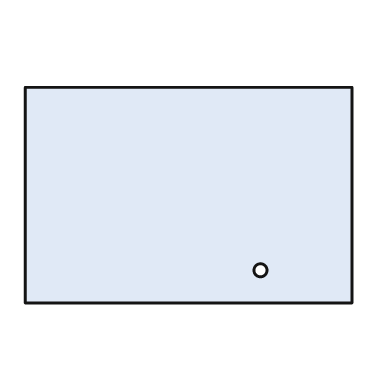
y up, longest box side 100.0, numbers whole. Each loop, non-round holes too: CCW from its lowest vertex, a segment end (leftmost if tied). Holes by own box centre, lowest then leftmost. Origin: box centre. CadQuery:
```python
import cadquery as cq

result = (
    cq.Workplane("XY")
    .moveTo(-50.0, -33.0)
    .lineTo(50.0, -33.0)
    .lineTo(50.0, 33.0)
    .lineTo(-50.0, 33.0)
    .close()
    .moveTo(22.0, -23.0)
    .circle(2.0)
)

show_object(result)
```